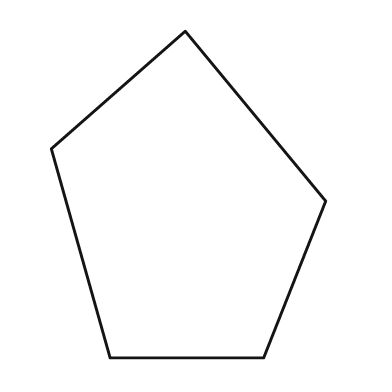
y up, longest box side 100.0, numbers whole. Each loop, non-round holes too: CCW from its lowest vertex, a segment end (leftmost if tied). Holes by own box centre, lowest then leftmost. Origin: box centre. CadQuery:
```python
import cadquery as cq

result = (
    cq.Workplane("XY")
    .moveTo(-24.0, -50.0)
    .lineTo(23.0, -50.0)
    .lineTo(42.0, -2.0)
    .lineTo(-1.0, 50.0)
    .lineTo(-42.0, 14.0)
    .close()
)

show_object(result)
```